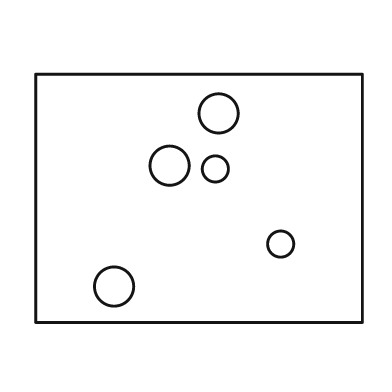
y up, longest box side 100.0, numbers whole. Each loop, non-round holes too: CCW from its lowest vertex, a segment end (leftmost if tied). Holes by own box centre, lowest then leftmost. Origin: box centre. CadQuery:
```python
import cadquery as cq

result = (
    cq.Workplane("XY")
    .moveTo(-50.0, -38.0)
    .lineTo(50.0, -38.0)
    .lineTo(50.0, 38.0)
    .lineTo(-50.0, 38.0)
    .close()
    .moveTo(-26.0, -27.0)
    .circle(6.0)
    .moveTo(25.0, -14.0)
    .circle(4.0)
    .moveTo(5.0, 9.0)
    .circle(4.0)
    .moveTo(-9.0, 10.0)
    .circle(6.0)
    .moveTo(6.0, 26.0)
    .circle(6.0)
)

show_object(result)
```